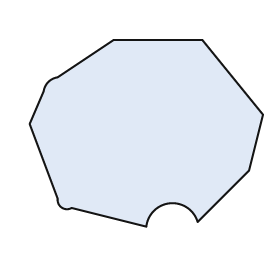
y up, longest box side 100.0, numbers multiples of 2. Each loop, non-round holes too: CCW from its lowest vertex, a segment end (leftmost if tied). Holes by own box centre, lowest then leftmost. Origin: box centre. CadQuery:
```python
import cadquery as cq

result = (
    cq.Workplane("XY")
    .moveTo(0.0, -40.0)
    .threePointArc((10.0, -30.0), (22.0, -38.0))
    .lineTo(44.0, -16.0)
    .lineTo(50.0, 8.0)
    .lineTo(24.0, 40.0)
    .lineTo(-14.0, 40.0)
    .lineTo(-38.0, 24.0)
    .threePointArc((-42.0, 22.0), (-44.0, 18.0))
    .lineTo(-50.0, 4.0)
    .lineTo(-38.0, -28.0)
    .threePointArc((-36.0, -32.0), (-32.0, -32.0))
    .close()
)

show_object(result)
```